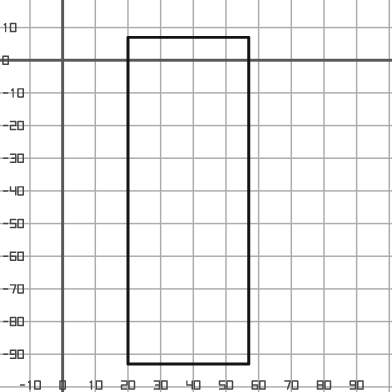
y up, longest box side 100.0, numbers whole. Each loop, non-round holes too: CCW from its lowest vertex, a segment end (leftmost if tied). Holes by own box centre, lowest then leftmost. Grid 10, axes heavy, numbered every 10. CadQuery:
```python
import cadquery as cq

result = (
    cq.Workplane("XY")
    .moveTo(20.0, -93.0)
    .lineTo(57.0, -93.0)
    .lineTo(57.0, 7.0)
    .lineTo(20.0, 7.0)
    .close()
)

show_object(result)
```